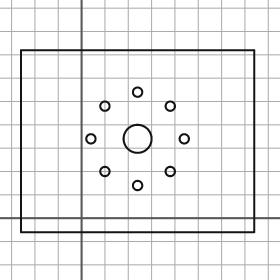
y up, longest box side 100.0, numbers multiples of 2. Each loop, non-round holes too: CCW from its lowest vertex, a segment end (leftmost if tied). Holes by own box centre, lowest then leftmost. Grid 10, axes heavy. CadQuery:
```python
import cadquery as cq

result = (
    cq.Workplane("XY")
    .moveTo(-26.0, -6.0)
    .lineTo(74.0, -6.0)
    .lineTo(74.0, 72.0)
    .lineTo(-26.0, 72.0)
    .close()
    .moveTo(24.0, 14.0)
    .circle(2.0)
    .moveTo(10.0, 20.0)
    .circle(2.0)
    .moveTo(38.0, 20.0)
    .circle(2.0)
    .moveTo(4.0, 34.0)
    .circle(2.0)
    .moveTo(24.0, 34.0)
    .circle(6.0)
    .moveTo(44.0, 34.0)
    .circle(2.0)
    .moveTo(10.0, 48.0)
    .circle(2.0)
    .moveTo(38.0, 48.0)
    .circle(2.0)
    .moveTo(24.0, 54.0)
    .circle(2.0)
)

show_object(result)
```